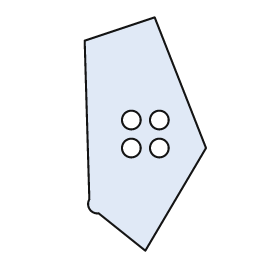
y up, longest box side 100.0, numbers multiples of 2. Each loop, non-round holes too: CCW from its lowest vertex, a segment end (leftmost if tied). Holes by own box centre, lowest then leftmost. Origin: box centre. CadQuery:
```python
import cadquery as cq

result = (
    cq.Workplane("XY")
    .moveTo(0.0, -50.0)
    .lineTo(26.0, -6.0)
    .lineTo(4.0, 50.0)
    .lineTo(-26.0, 40.0)
    .lineTo(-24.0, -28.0)
    .threePointArc((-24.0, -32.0), (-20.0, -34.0))
    .close()
    .moveTo(-6.0, -6.0)
    .circle(4.0)
    .moveTo(6.0, -6.0)
    .circle(4.0)
    .moveTo(-6.0, 6.0)
    .circle(4.0)
    .moveTo(6.0, 6.0)
    .circle(4.0)
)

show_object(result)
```